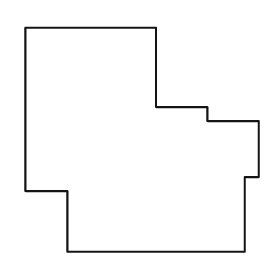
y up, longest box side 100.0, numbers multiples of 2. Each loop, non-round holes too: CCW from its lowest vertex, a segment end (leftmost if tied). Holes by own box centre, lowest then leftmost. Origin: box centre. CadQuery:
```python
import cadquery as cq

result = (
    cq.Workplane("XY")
    .moveTo(-32.0, -48.0)
    .lineTo(44.0, -48.0)
    .lineTo(44.0, -16.0)
    .lineTo(50.0, -16.0)
    .lineTo(50.0, 8.0)
    .lineTo(28.0, 8.0)
    .lineTo(28.0, 14.0)
    .lineTo(6.0, 14.0)
    .lineTo(6.0, 48.0)
    .lineTo(-50.0, 48.0)
    .lineTo(-50.0, -22.0)
    .lineTo(-32.0, -22.0)
    .close()
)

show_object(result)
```